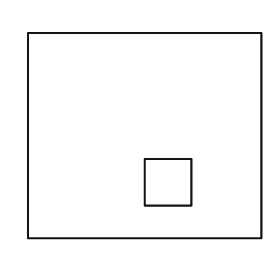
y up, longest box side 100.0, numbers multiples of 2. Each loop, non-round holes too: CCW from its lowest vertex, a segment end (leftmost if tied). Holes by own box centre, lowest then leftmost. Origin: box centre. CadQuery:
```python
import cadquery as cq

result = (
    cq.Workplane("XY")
    .moveTo(-50.0, -44.0)
    .lineTo(50.0, -44.0)
    .lineTo(50.0, 44.0)
    .lineTo(-50.0, 44.0)
    .close()
    .moveTo(0.0, -30.0)
    .lineTo(20.0, -30.0)
    .lineTo(20.0, -10.0)
    .lineTo(0.0, -10.0)
    .close()
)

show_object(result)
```